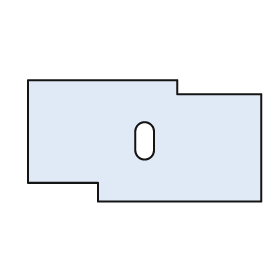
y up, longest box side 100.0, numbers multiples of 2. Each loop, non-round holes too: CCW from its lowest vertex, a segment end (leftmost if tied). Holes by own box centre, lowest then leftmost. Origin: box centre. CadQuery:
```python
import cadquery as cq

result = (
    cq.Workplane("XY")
    .moveTo(-20.0, -26.0)
    .lineTo(50.0, -26.0)
    .lineTo(50.0, 20.0)
    .lineTo(14.0, 20.0)
    .lineTo(14.0, 26.0)
    .lineTo(-50.0, 26.0)
    .lineTo(-50.0, -18.0)
    .lineTo(-20.0, -18.0)
    .close()
    .moveTo(-4.0, -4.0)
    .threePointArc((0.0, -8.0), (4.0, -4.0))
    .lineTo(4.0, 4.0)
    .threePointArc((0.0, 8.0), (-4.0, 4.0))
    .close()
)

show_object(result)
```